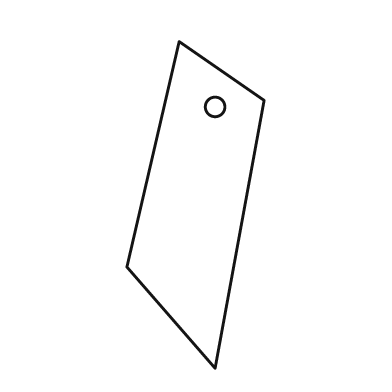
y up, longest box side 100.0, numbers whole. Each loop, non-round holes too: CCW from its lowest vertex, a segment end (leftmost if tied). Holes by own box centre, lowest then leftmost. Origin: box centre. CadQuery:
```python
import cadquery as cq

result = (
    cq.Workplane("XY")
    .moveTo(6.0, -50.0)
    .lineTo(21.0, 32.0)
    .lineTo(-5.0, 50.0)
    .lineTo(-21.0, -19.0)
    .close()
    .moveTo(6.0, 30.0)
    .circle(3.0)
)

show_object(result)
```